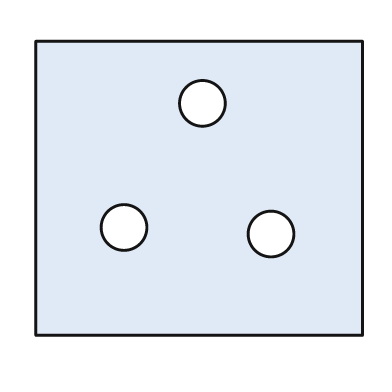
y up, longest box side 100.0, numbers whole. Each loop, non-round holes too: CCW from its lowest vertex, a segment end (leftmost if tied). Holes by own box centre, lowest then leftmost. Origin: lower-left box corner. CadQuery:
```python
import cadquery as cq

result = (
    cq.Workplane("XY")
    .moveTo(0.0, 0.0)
    .lineTo(100.0, 0.0)
    .lineTo(100.0, 90.0)
    .lineTo(0.0, 90.0)
    .close()
    .moveTo(72.0, 31.0)
    .circle(7.0)
    .moveTo(27.0, 33.0)
    .circle(7.0)
    .moveTo(51.0, 71.0)
    .circle(7.0)
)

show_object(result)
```